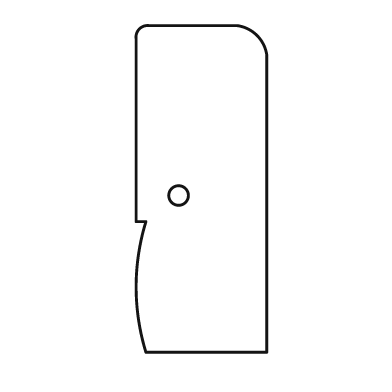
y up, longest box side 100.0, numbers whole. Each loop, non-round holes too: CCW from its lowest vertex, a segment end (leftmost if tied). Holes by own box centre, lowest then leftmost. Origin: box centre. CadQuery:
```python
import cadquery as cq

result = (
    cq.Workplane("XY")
    .moveTo(-17.0, -50.0)
    .lineTo(20.0, -50.0)
    .lineTo(20.0, 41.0)
    .threePointArc((17.0, 47.0), (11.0, 50.0))
    .lineTo(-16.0, 50.0)
    .threePointArc((-19.0, 49.0), (-20.0, 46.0))
    .lineTo(-20.0, -10.0)
    .lineTo(-17.0, -10.0)
    .threePointArc((-20.0, -30.0), (-17.0, -50.0))
    .close()
    .moveTo(-7.0, -2.0)
    .circle(3.0)
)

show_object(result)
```